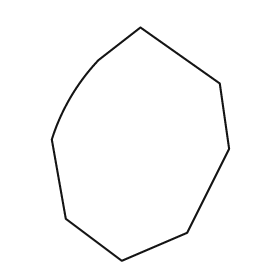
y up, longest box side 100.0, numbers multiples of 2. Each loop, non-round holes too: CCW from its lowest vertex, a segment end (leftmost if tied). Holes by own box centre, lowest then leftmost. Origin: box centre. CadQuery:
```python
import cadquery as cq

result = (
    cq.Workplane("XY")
    .moveTo(-8.0, -50.0)
    .lineTo(20.0, -38.0)
    .lineTo(38.0, -2.0)
    .lineTo(34.0, 26.0)
    .lineTo(0.0, 50.0)
    .lineTo(-18.0, 36.0)
    .threePointArc((-30.0, 20.0), (-38.0, 2.0))
    .lineTo(-32.0, -32.0)
    .close()
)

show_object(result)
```